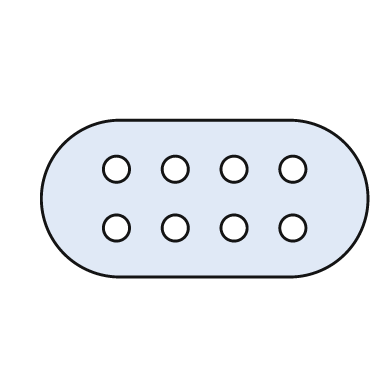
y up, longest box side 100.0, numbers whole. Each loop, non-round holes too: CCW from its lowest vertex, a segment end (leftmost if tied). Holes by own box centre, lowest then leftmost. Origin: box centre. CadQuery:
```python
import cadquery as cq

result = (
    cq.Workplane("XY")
    .moveTo(-26.0, -24.0)
    .lineTo(26.0, -24.0)
    .threePointArc((50.0, 0.0), (26.0, 24.0))
    .lineTo(-26.0, 24.0)
    .threePointArc((-50.0, 0.0), (-26.0, -24.0))
    .close()
    .moveTo(-27.0, -9.0)
    .circle(4.0)
    .moveTo(-9.0, -9.0)
    .circle(4.0)
    .moveTo(9.0, -9.0)
    .circle(4.0)
    .moveTo(27.0, -9.0)
    .circle(4.0)
    .moveTo(-27.0, 9.0)
    .circle(4.0)
    .moveTo(-9.0, 9.0)
    .circle(4.0)
    .moveTo(9.0, 9.0)
    .circle(4.0)
    .moveTo(27.0, 9.0)
    .circle(4.0)
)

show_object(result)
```